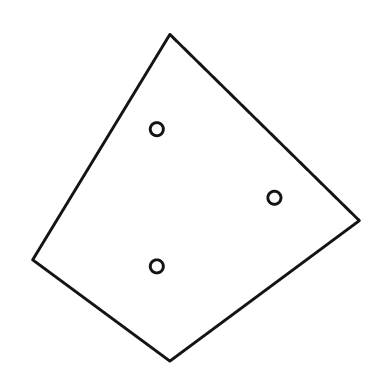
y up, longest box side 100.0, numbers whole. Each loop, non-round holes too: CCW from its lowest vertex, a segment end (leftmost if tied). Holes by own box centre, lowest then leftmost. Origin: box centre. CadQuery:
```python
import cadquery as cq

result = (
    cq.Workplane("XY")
    .moveTo(-8.0, -50.0)
    .lineTo(50.0, -7.0)
    .lineTo(-8.0, 50.0)
    .lineTo(-50.0, -19.0)
    .close()
    .moveTo(-12.0, -21.0)
    .circle(2.0)
    .moveTo(24.0, 0.0)
    .circle(2.0)
    .moveTo(-12.0, 21.0)
    .circle(2.0)
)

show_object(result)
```